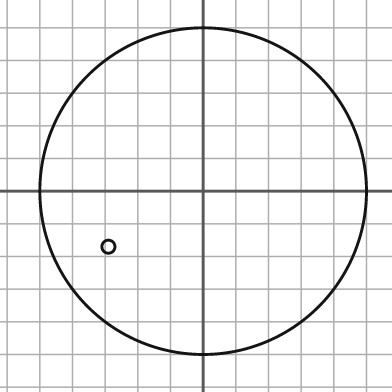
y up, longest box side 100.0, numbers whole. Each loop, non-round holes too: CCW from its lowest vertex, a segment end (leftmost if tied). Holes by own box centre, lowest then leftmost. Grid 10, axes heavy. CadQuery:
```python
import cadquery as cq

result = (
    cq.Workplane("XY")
    .moveTo(0.0, 0.0)
    .circle(50.0)
    .moveTo(-29.0, -17.0)
    .circle(2.0)
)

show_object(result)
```